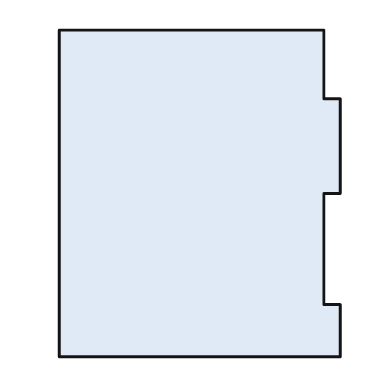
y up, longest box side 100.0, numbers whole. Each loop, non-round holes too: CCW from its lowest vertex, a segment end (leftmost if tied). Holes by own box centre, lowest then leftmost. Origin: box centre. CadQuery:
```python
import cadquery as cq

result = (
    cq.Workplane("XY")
    .moveTo(-43.0, -50.0)
    .lineTo(43.0, -50.0)
    .lineTo(43.0, -34.0)
    .lineTo(38.0, -34.0)
    .lineTo(38.0, 0.0)
    .lineTo(43.0, 0.0)
    .lineTo(43.0, 29.0)
    .lineTo(38.0, 29.0)
    .lineTo(38.0, 50.0)
    .lineTo(-43.0, 50.0)
    .close()
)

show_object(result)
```